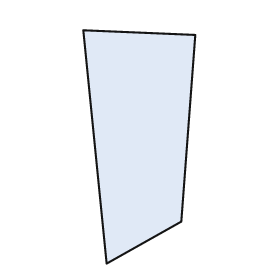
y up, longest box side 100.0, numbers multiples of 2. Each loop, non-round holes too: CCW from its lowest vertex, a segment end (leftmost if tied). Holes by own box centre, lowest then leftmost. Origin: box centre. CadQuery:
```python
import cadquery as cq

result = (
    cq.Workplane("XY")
    .moveTo(-14.0, -50.0)
    .lineTo(18.0, -32.0)
    .lineTo(24.0, 48.0)
    .lineTo(-24.0, 50.0)
    .close()
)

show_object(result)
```